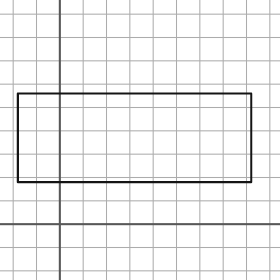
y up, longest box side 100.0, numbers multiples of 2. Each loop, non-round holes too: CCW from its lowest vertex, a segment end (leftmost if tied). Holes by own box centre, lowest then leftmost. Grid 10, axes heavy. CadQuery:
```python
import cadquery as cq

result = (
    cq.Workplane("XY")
    .moveTo(-18.0, 18.0)
    .lineTo(82.0, 18.0)
    .lineTo(82.0, 56.0)
    .lineTo(-18.0, 56.0)
    .close()
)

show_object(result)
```